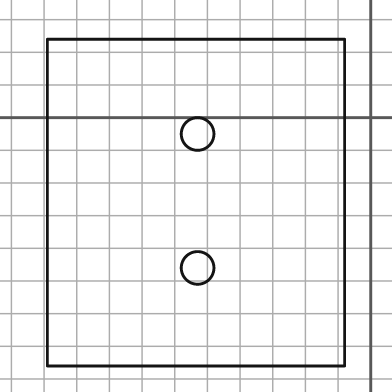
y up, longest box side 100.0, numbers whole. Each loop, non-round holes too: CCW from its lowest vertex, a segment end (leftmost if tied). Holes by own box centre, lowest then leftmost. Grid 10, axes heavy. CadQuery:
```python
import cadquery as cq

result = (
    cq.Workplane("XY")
    .moveTo(-99.0, -76.0)
    .lineTo(-8.0, -76.0)
    .lineTo(-8.0, 24.0)
    .lineTo(-99.0, 24.0)
    .close()
    .moveTo(-53.0, -46.0)
    .circle(5.0)
    .moveTo(-53.0, -5.0)
    .circle(5.0)
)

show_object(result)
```